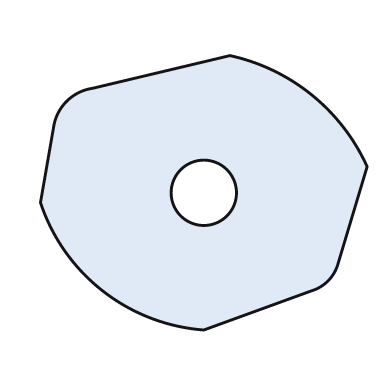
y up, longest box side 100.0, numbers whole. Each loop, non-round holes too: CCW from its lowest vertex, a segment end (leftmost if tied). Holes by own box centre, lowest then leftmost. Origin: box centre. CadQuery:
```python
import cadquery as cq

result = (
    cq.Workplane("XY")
    .moveTo(0.0, -42.0)
    .lineTo(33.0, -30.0)
    .threePointArc((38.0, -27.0), (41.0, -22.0))
    .lineTo(50.0, 8.0)
    .threePointArc((33.0, 30.0), (8.0, 42.0))
    .lineTo(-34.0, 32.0)
    .threePointArc((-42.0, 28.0), (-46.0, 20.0))
    .lineTo(-50.0, -3.0)
    .threePointArc((-31.0, -30.0), (0.0, -42.0))
    .close()
    .moveTo(0.0, 0.0)
    .circle(10.0)
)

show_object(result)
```